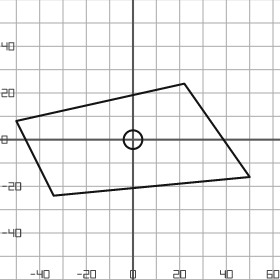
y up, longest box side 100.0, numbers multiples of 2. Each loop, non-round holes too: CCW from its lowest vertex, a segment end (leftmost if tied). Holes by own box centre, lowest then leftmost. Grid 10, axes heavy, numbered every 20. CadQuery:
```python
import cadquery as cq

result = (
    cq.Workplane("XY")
    .moveTo(-34.0, -24.0)
    .lineTo(50.0, -16.0)
    .lineTo(22.0, 24.0)
    .lineTo(-50.0, 8.0)
    .close()
    .moveTo(0.0, 0.0)
    .circle(4.0)
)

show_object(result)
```